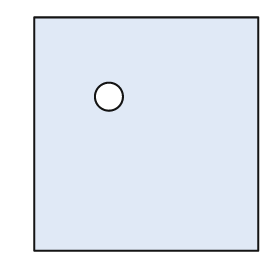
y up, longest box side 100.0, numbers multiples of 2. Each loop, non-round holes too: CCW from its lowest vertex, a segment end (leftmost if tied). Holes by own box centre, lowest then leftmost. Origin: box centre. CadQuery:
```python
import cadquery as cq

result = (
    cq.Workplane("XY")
    .moveTo(-48.0, -50.0)
    .lineTo(48.0, -50.0)
    .lineTo(48.0, 50.0)
    .lineTo(-48.0, 50.0)
    .close()
    .moveTo(-16.0, 16.0)
    .circle(6.0)
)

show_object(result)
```